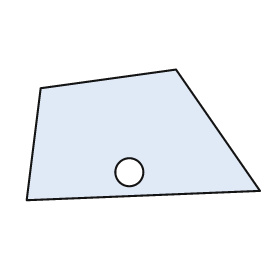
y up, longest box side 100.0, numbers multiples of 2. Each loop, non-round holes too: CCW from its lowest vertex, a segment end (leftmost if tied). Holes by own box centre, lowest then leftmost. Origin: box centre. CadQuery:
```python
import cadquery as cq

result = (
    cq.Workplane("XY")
    .moveTo(-50.0, -28.0)
    .lineTo(50.0, -24.0)
    .lineTo(14.0, 28.0)
    .lineTo(-44.0, 20.0)
    .close()
    .moveTo(-6.0, -16.0)
    .circle(6.0)
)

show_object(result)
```